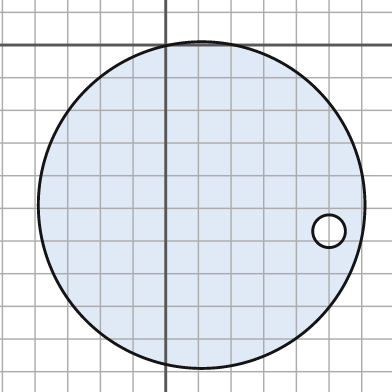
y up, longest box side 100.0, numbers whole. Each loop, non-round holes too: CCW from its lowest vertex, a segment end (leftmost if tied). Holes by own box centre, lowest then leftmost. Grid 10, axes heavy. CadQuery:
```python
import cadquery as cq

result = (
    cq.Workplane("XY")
    .moveTo(11.0, -49.0)
    .circle(50.0)
    .moveTo(50.0, -57.0)
    .circle(5.0)
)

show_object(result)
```